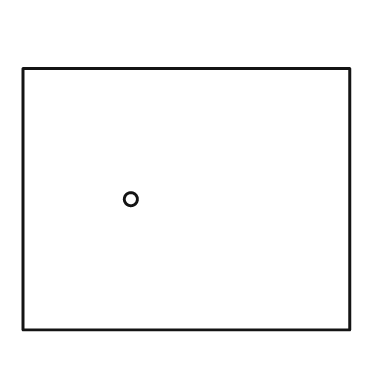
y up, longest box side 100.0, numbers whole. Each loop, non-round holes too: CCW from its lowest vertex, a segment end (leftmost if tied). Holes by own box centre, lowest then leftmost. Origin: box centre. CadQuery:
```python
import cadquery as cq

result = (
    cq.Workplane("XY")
    .moveTo(-50.0, -40.0)
    .lineTo(50.0, -40.0)
    .lineTo(50.0, 40.0)
    .lineTo(-50.0, 40.0)
    .close()
    .moveTo(-17.0, 0.0)
    .circle(2.0)
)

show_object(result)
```